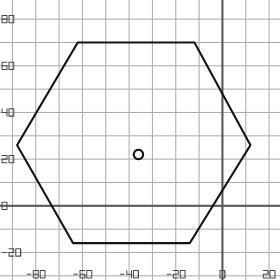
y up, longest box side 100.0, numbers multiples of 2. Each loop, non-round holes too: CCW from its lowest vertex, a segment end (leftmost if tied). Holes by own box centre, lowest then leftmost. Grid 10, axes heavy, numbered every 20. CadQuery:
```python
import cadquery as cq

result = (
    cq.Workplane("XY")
    .moveTo(-64.0, -16.0)
    .lineTo(-14.0, -16.0)
    .lineTo(12.0, 26.0)
    .lineTo(-12.0, 70.0)
    .lineTo(-62.0, 70.0)
    .lineTo(-88.0, 26.0)
    .close()
    .moveTo(-36.0, 22.0)
    .circle(2.0)
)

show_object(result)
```